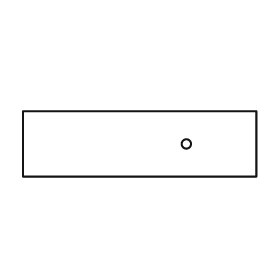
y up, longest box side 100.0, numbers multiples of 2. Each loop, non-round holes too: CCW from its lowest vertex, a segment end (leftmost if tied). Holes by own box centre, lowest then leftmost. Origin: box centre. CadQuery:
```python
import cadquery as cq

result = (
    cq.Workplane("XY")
    .moveTo(-50.0, -14.0)
    .lineTo(50.0, -14.0)
    .lineTo(50.0, 14.0)
    .lineTo(-50.0, 14.0)
    .close()
    .moveTo(20.0, 0.0)
    .circle(2.0)
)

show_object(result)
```